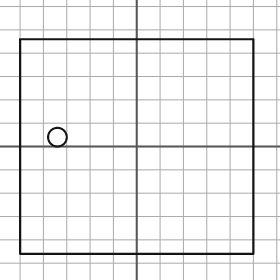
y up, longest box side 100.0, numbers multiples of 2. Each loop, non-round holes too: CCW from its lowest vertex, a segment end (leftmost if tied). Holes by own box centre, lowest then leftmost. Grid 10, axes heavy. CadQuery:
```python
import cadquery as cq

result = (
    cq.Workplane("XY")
    .moveTo(-50.0, -46.0)
    .lineTo(50.0, -46.0)
    .lineTo(50.0, 46.0)
    .lineTo(-50.0, 46.0)
    .close()
    .moveTo(-34.0, 4.0)
    .circle(4.0)
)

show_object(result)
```